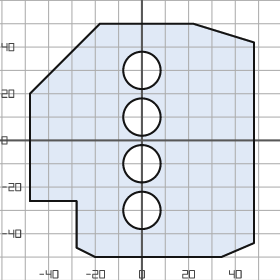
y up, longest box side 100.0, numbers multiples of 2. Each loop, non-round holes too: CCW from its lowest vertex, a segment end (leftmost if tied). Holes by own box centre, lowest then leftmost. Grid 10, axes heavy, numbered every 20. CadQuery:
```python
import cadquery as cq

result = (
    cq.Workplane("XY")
    .moveTo(-20.0, -50.0)
    .lineTo(34.0, -50.0)
    .lineTo(48.0, -44.0)
    .lineTo(48.0, 42.0)
    .lineTo(22.0, 50.0)
    .lineTo(-18.0, 50.0)
    .lineTo(-48.0, 20.0)
    .lineTo(-48.0, -26.0)
    .lineTo(-28.0, -26.0)
    .lineTo(-28.0, -46.0)
    .close()
    .moveTo(0.0, -30.0)
    .circle(8.0)
    .moveTo(0.0, -10.0)
    .circle(8.0)
    .moveTo(0.0, 10.0)
    .circle(8.0)
    .moveTo(0.0, 30.0)
    .circle(8.0)
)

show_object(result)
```